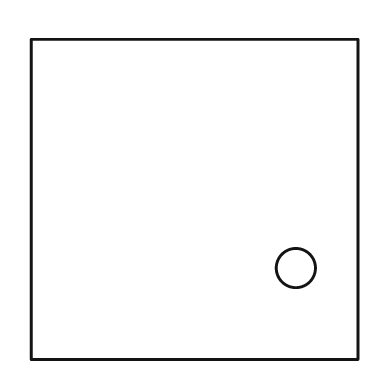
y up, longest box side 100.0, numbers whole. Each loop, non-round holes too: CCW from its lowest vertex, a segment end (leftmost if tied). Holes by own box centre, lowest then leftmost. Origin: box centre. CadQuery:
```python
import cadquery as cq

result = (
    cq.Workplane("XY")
    .moveTo(-50.0, -49.0)
    .lineTo(50.0, -49.0)
    .lineTo(50.0, 49.0)
    .lineTo(-50.0, 49.0)
    .close()
    .moveTo(31.0, -21.0)
    .circle(6.0)
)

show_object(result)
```